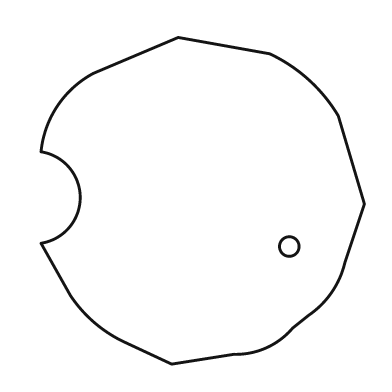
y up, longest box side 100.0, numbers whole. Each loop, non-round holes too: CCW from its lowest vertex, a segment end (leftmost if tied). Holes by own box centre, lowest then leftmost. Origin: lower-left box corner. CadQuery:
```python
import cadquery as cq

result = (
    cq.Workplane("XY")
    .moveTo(40.0, 0.0)
    .lineTo(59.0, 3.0)
    .threePointArc((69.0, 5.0), (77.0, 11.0))
    .lineTo(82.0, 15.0)
    .threePointArc((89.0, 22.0), (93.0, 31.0))
    .lineTo(99.0, 49.0)
    .lineTo(91.0, 76.0)
    .threePointArc((82.0, 87.0), (70.0, 95.0))
    .lineTo(42.0, 100.0)
    .lineTo(16.0, 89.0)
    .threePointArc((5.0, 79.0), (0.0, 65.0))
    .threePointArc((12.0, 51.0), (0.0, 37.0))
    .lineTo(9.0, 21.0)
    .threePointArc((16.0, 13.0), (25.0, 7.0))
    .close()
    .moveTo(76.0, 36.0)
    .circle(3.0)
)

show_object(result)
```